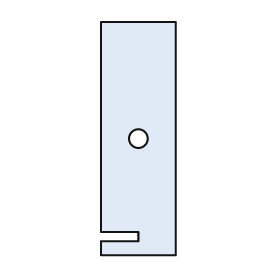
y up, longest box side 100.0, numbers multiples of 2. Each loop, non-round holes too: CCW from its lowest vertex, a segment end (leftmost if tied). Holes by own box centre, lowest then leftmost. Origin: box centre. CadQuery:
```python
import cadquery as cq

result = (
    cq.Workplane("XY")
    .moveTo(-16.0, -50.0)
    .lineTo(16.0, -50.0)
    .lineTo(16.0, 50.0)
    .lineTo(-16.0, 50.0)
    .lineTo(-16.0, -40.0)
    .lineTo(0.0, -40.0)
    .lineTo(0.0, -44.0)
    .lineTo(-16.0, -44.0)
    .close()
    .moveTo(0.0, 0.0)
    .circle(4.0)
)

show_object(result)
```